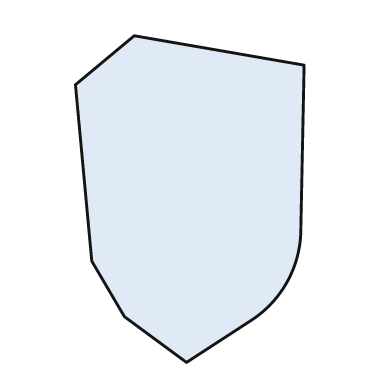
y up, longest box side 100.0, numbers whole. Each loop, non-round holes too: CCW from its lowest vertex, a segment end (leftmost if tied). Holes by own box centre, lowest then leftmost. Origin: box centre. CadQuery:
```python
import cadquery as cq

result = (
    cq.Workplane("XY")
    .moveTo(-1.0, -50.0)
    .lineTo(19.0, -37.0)
    .threePointArc((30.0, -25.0), (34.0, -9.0))
    .lineTo(35.0, 41.0)
    .lineTo(-17.0, 50.0)
    .lineTo(-35.0, 35.0)
    .lineTo(-30.0, -19.0)
    .lineTo(-20.0, -36.0)
    .close()
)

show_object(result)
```